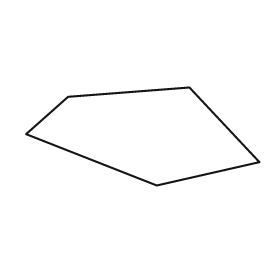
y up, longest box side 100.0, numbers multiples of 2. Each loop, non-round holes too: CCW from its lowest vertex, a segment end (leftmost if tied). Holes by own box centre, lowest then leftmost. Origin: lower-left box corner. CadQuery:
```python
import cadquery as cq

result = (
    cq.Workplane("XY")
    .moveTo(56.0, 0.0)
    .lineTo(100.0, 10.0)
    .lineTo(70.0, 42.0)
    .lineTo(18.0, 38.0)
    .lineTo(0.0, 22.0)
    .close()
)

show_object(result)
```